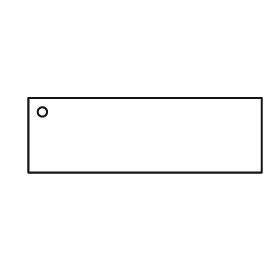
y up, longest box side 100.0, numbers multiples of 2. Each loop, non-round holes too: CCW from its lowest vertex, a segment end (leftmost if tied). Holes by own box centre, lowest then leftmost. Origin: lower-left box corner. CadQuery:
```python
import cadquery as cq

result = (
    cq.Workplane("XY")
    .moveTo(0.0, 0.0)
    .lineTo(100.0, 0.0)
    .lineTo(100.0, 32.0)
    .lineTo(0.0, 32.0)
    .close()
    .moveTo(6.0, 26.0)
    .circle(2.0)
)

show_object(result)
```